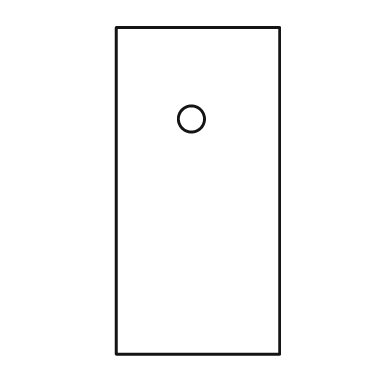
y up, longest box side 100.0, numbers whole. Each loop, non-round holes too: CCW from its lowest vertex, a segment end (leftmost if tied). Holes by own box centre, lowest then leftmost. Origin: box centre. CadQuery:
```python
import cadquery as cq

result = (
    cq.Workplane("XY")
    .moveTo(-25.0, -50.0)
    .lineTo(25.0, -50.0)
    .lineTo(25.0, 50.0)
    .lineTo(-25.0, 50.0)
    .close()
    .moveTo(-2.0, 22.0)
    .circle(4.0)
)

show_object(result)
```